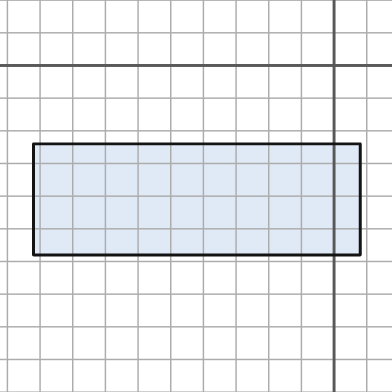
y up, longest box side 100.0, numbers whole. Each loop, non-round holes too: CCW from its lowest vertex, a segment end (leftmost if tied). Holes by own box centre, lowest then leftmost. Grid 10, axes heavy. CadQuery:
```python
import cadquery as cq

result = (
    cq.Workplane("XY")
    .moveTo(-92.0, -58.0)
    .lineTo(8.0, -58.0)
    .lineTo(8.0, -24.0)
    .lineTo(-92.0, -24.0)
    .close()
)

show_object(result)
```